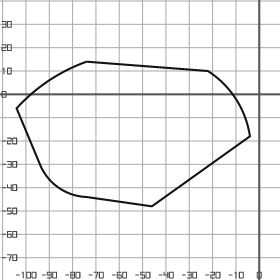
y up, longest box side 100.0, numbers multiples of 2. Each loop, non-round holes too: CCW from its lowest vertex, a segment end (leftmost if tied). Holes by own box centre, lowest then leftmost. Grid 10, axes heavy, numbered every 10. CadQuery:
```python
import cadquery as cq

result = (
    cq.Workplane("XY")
    .moveTo(-46.0, -48.0)
    .lineTo(-4.0, -18.0)
    .threePointArc((-10.0, -2.0), (-22.0, 10.0))
    .lineTo(-74.0, 14.0)
    .threePointArc((-90.0, 6.0), (-104.0, -6.0))
    .lineTo(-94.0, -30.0)
    .threePointArc((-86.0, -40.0), (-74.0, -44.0))
    .close()
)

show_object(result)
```